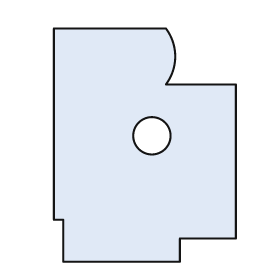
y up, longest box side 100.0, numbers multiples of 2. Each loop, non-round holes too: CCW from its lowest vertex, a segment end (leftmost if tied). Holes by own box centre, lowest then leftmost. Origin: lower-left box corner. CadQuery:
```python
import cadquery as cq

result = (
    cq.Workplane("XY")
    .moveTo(4.0, 0.0)
    .lineTo(54.0, 0.0)
    .lineTo(54.0, 10.0)
    .lineTo(78.0, 10.0)
    .lineTo(78.0, 76.0)
    .lineTo(48.0, 76.0)
    .threePointArc((52.0, 88.0), (48.0, 100.0))
    .lineTo(0.0, 100.0)
    .lineTo(0.0, 18.0)
    .lineTo(4.0, 18.0)
    .close()
    .moveTo(42.0, 54.0)
    .circle(8.0)
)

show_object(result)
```